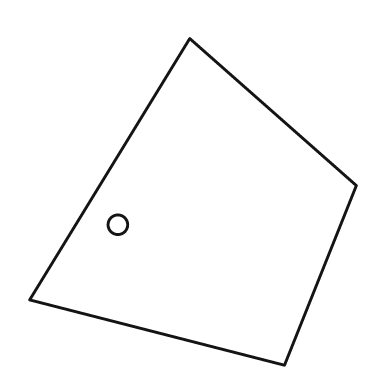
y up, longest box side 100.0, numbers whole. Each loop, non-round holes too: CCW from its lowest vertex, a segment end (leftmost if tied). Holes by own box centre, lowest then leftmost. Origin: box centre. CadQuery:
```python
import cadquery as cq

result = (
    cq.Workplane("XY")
    .moveTo(28.0, -50.0)
    .lineTo(50.0, 5.0)
    .lineTo(-1.0, 50.0)
    .lineTo(-50.0, -30.0)
    .close()
    .moveTo(-23.0, -7.0)
    .circle(3.0)
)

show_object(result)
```